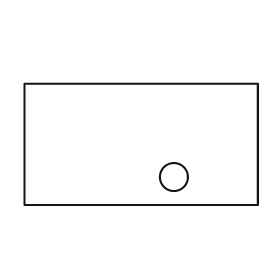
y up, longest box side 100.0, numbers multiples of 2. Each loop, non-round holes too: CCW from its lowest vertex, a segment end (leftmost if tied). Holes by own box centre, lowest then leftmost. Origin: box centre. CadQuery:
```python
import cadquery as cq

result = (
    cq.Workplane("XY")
    .moveTo(-50.0, -26.0)
    .lineTo(50.0, -26.0)
    .lineTo(50.0, 26.0)
    .lineTo(-50.0, 26.0)
    .close()
    .moveTo(14.0, -14.0)
    .circle(6.0)
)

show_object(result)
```